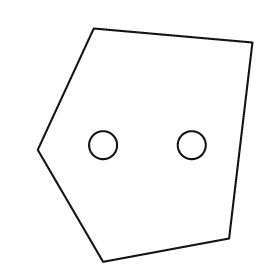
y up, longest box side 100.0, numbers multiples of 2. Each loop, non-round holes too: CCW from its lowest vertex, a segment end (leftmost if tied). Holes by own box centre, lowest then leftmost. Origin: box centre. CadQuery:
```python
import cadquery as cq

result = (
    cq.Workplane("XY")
    .moveTo(-18.0, -50.0)
    .lineTo(36.0, -40.0)
    .lineTo(46.0, 44.0)
    .lineTo(-22.0, 50.0)
    .lineTo(-46.0, -2.0)
    .close()
    .moveTo(-18.0, 0.0)
    .circle(6.0)
    .moveTo(20.0, 0.0)
    .circle(6.0)
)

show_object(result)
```